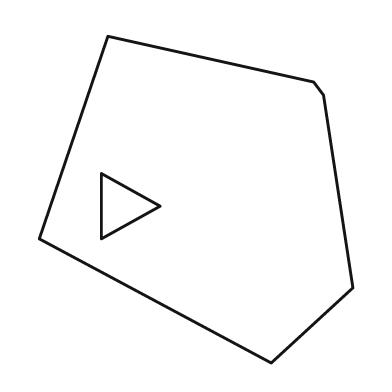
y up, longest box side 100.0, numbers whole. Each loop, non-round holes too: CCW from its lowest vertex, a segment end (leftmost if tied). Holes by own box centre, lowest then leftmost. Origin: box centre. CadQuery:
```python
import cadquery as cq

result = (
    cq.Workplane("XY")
    .moveTo(23.0, -50.0)
    .lineTo(48.0, -27.0)
    .lineTo(39.0, 32.0)
    .lineTo(36.0, 36.0)
    .lineTo(-27.0, 50.0)
    .lineTo(-48.0, -12.0)
    .close()
    .moveTo(-29.0, -12.0)
    .lineTo(-11.0, -2.0)
    .lineTo(-29.0, 8.0)
    .close()
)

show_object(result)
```